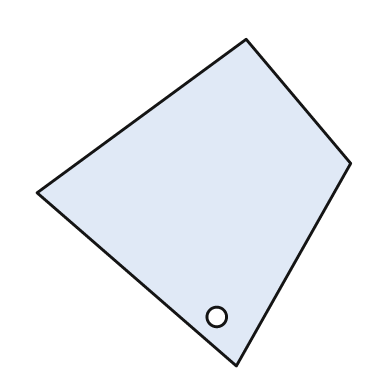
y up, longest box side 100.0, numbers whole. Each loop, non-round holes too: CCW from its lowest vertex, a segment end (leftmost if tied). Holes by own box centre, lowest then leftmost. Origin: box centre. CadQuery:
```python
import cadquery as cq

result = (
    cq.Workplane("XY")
    .moveTo(13.0, -50.0)
    .lineTo(48.0, 12.0)
    .lineTo(16.0, 50.0)
    .lineTo(-48.0, 3.0)
    .close()
    .moveTo(7.0, -35.0)
    .circle(3.0)
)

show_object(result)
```